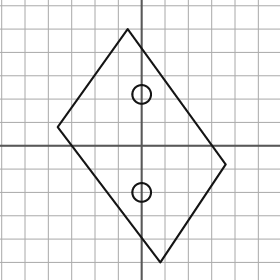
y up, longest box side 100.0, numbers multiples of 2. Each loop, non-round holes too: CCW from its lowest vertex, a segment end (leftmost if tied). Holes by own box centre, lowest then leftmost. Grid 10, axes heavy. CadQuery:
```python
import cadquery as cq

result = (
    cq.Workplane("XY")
    .moveTo(8.0, -50.0)
    .lineTo(36.0, -8.0)
    .lineTo(-6.0, 50.0)
    .lineTo(-36.0, 8.0)
    .close()
    .moveTo(0.0, -20.0)
    .circle(4.0)
    .moveTo(0.0, 22.0)
    .circle(4.0)
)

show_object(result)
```